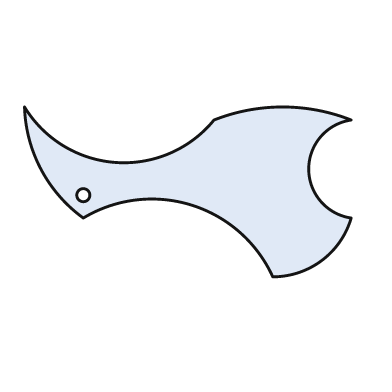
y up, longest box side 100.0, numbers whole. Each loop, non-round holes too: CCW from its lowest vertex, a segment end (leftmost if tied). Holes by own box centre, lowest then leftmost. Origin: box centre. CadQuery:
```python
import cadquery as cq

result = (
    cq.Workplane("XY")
    .moveTo(26.0, -26.0)
    .threePointArc((41.0, -21.0), (50.0, -8.0))
    .threePointArc((37.0, 7.0), (50.0, 22.0))
    .threePointArc((29.0, 26.0), (8.0, 22.0))
    .threePointArc((-22.0, 9.0), (-50.0, 26.0))
    .threePointArc((-45.0, 7.0), (-32.0, -8.0))
    .threePointArc((1.0, -4.0), (26.0, -26.0))
    .close()
    .moveTo(-32.0, -1.0)
    .circle(2.0)
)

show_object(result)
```